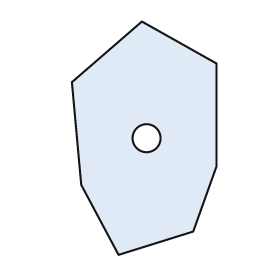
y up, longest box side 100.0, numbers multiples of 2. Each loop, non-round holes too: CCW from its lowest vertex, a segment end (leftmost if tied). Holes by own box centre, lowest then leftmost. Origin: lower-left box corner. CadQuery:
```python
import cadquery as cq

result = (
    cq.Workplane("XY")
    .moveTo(20.0, 0.0)
    .lineTo(52.0, 10.0)
    .lineTo(62.0, 38.0)
    .lineTo(62.0, 82.0)
    .lineTo(30.0, 100.0)
    .lineTo(0.0, 74.0)
    .lineTo(4.0, 30.0)
    .close()
    .moveTo(32.0, 50.0)
    .circle(6.0)
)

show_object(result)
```